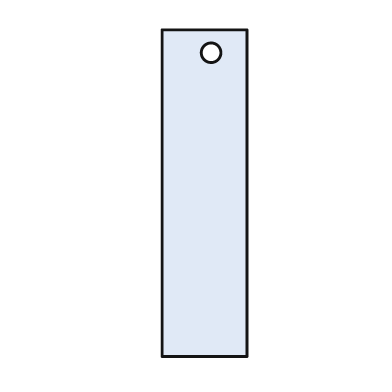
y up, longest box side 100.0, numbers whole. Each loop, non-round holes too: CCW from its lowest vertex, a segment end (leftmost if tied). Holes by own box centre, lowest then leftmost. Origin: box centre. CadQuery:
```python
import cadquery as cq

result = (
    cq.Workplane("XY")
    .moveTo(-13.0, -50.0)
    .lineTo(13.0, -50.0)
    .lineTo(13.0, 50.0)
    .lineTo(-13.0, 50.0)
    .close()
    .moveTo(2.0, 43.0)
    .circle(3.0)
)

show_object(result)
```